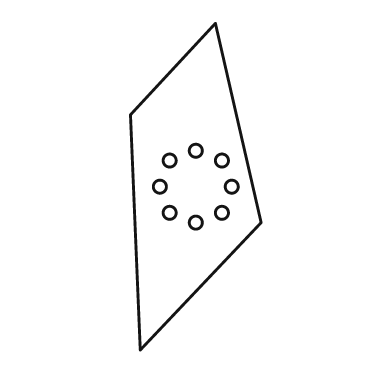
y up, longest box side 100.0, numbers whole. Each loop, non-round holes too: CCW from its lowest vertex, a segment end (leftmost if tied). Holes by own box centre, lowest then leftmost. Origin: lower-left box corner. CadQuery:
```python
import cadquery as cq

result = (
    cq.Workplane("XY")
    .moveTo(3.0, 0.0)
    .lineTo(40.0, 39.0)
    .lineTo(26.0, 100.0)
    .lineTo(0.0, 72.0)
    .close()
    .moveTo(20.0, 39.0)
    .circle(2.0)
    .moveTo(12.0, 42.0)
    .circle(2.0)
    .moveTo(28.0, 42.0)
    .circle(2.0)
    .moveTo(9.0, 50.0)
    .circle(2.0)
    .moveTo(31.0, 50.0)
    .circle(2.0)
    .moveTo(12.0, 58.0)
    .circle(2.0)
    .moveTo(28.0, 58.0)
    .circle(2.0)
    .moveTo(20.0, 61.0)
    .circle(2.0)
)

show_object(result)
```